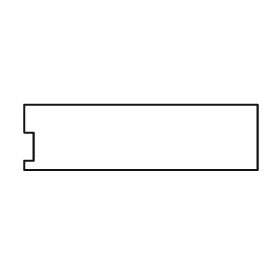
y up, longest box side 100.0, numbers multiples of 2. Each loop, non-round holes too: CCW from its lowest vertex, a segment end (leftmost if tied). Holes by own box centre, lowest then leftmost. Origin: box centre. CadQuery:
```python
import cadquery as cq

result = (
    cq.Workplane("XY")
    .moveTo(-50.0, -14.0)
    .lineTo(50.0, -14.0)
    .lineTo(50.0, 14.0)
    .lineTo(-50.0, 14.0)
    .lineTo(-50.0, 2.0)
    .lineTo(-46.0, 2.0)
    .lineTo(-46.0, -10.0)
    .lineTo(-50.0, -10.0)
    .close()
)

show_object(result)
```